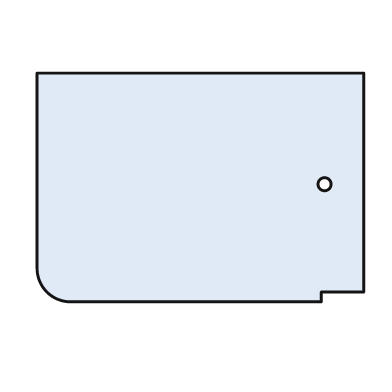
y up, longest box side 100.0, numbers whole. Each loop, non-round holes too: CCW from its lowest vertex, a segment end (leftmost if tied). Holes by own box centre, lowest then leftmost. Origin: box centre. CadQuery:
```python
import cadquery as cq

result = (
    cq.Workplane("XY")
    .moveTo(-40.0, -35.0)
    .lineTo(37.0, -35.0)
    .lineTo(37.0, -32.0)
    .lineTo(50.0, -32.0)
    .lineTo(50.0, 35.0)
    .lineTo(-50.0, 35.0)
    .lineTo(-50.0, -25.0)
    .threePointArc((-47.0, -32.0), (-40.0, -35.0))
    .close()
    .moveTo(38.0, 1.0)
    .circle(2.0)
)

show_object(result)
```